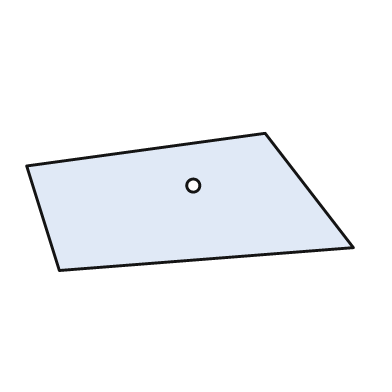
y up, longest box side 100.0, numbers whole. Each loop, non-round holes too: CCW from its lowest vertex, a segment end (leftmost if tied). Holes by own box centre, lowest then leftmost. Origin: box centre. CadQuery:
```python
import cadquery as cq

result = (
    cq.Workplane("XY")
    .moveTo(-40.0, -21.0)
    .lineTo(50.0, -14.0)
    .lineTo(23.0, 21.0)
    .lineTo(-50.0, 11.0)
    .close()
    .moveTo(1.0, 5.0)
    .circle(2.0)
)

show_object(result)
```